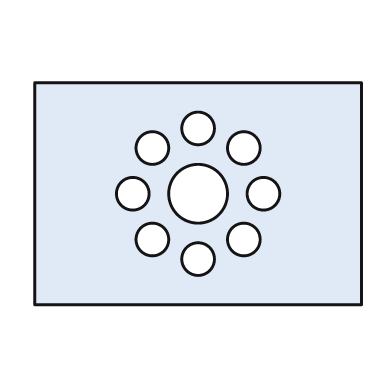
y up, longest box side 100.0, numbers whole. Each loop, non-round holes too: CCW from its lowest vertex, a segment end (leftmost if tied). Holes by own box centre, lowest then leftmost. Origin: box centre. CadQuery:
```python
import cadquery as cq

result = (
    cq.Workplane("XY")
    .moveTo(-50.0, -34.0)
    .lineTo(50.0, -34.0)
    .lineTo(50.0, 34.0)
    .lineTo(-50.0, 34.0)
    .close()
    .moveTo(0.0, -20.0)
    .circle(5.0)
    .moveTo(-14.0, -14.0)
    .circle(5.0)
    .moveTo(14.0, -14.0)
    .circle(5.0)
    .moveTo(-20.0, 0.0)
    .circle(5.0)
    .moveTo(0.0, 0.0)
    .circle(9.0)
    .moveTo(20.0, 0.0)
    .circle(5.0)
    .moveTo(-14.0, 14.0)
    .circle(5.0)
    .moveTo(14.0, 14.0)
    .circle(5.0)
    .moveTo(0.0, 20.0)
    .circle(5.0)
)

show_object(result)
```